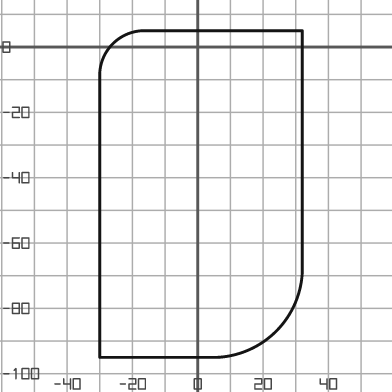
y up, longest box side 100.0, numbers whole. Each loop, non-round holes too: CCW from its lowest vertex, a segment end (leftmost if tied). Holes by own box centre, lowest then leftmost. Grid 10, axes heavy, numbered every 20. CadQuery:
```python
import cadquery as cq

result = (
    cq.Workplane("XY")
    .moveTo(-30.0, -95.0)
    .lineTo(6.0, -95.0)
    .threePointArc((24.0, -87.0), (32.0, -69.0))
    .lineTo(32.0, 5.0)
    .lineTo(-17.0, 5.0)
    .threePointArc((-26.0, 1.0), (-30.0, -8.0))
    .close()
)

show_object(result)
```